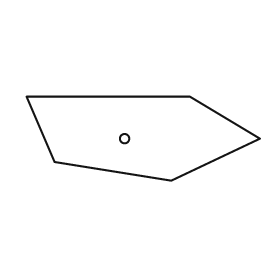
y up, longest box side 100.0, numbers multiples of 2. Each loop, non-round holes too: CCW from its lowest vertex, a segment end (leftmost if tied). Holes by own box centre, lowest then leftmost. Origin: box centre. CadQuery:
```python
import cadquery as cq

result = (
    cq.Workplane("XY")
    .moveTo(12.0, -18.0)
    .lineTo(50.0, 0.0)
    .lineTo(20.0, 18.0)
    .lineTo(-50.0, 18.0)
    .lineTo(-38.0, -10.0)
    .close()
    .moveTo(-8.0, 0.0)
    .circle(2.0)
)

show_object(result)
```